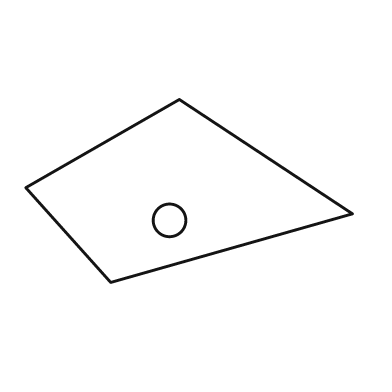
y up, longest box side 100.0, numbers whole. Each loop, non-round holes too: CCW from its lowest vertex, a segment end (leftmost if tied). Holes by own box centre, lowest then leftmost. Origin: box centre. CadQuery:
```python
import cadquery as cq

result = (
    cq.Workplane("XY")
    .moveTo(-24.0, -28.0)
    .lineTo(50.0, -7.0)
    .lineTo(-3.0, 28.0)
    .lineTo(-50.0, 1.0)
    .close()
    .moveTo(-6.0, -9.0)
    .circle(5.0)
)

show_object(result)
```